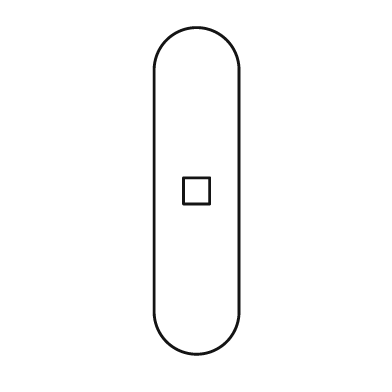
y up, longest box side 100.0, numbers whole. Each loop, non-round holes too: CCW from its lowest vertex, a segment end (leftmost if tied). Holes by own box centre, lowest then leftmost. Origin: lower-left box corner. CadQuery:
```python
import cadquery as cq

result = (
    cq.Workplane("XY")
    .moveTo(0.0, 13.0)
    .threePointArc((13.0, 0.0), (26.0, 13.0))
    .lineTo(26.0, 87.0)
    .threePointArc((13.0, 100.0), (0.0, 87.0))
    .close()
    .moveTo(9.0, 46.0)
    .lineTo(17.0, 46.0)
    .lineTo(17.0, 54.0)
    .lineTo(9.0, 54.0)
    .close()
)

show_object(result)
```